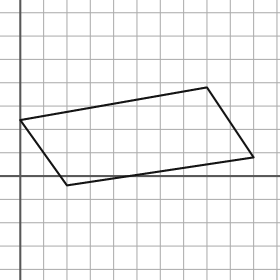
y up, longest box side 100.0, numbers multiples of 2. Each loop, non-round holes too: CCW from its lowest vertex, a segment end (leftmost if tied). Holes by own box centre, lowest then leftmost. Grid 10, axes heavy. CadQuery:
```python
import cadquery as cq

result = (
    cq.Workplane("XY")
    .moveTo(20.0, -4.0)
    .lineTo(100.0, 8.0)
    .lineTo(80.0, 38.0)
    .lineTo(0.0, 24.0)
    .close()
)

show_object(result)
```